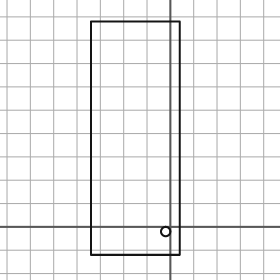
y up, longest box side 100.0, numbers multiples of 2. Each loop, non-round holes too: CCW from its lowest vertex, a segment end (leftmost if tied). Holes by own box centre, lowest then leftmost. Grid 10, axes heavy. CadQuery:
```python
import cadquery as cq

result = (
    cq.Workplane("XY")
    .moveTo(-34.0, -12.0)
    .lineTo(4.0, -12.0)
    .lineTo(4.0, 88.0)
    .lineTo(-34.0, 88.0)
    .close()
    .moveTo(-2.0, -2.0)
    .circle(2.0)
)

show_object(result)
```